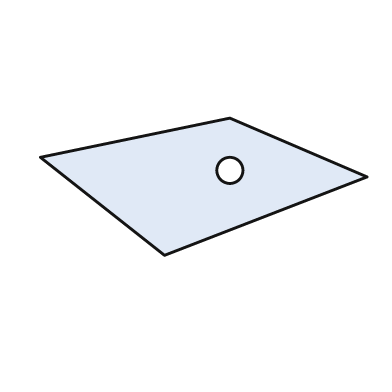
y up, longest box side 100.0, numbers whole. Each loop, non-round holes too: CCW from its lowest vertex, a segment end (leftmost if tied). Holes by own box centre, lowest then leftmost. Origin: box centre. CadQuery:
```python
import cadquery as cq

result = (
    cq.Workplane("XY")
    .moveTo(-12.0, -21.0)
    .lineTo(50.0, 3.0)
    .lineTo(8.0, 21.0)
    .lineTo(-50.0, 9.0)
    .close()
    .moveTo(8.0, 5.0)
    .circle(4.0)
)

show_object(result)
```